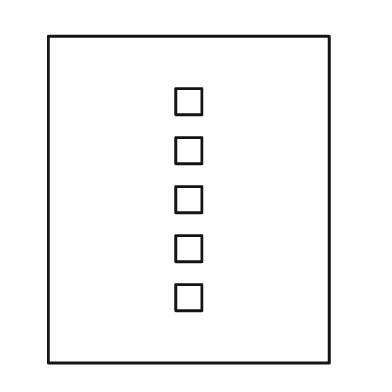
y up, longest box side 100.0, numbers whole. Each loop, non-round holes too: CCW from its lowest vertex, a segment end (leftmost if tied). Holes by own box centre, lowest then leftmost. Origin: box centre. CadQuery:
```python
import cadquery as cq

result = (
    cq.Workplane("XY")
    .moveTo(-43.0, -50.0)
    .lineTo(43.0, -50.0)
    .lineTo(43.0, 50.0)
    .lineTo(-43.0, 50.0)
    .close()
    .moveTo(-4.0, -34.0)
    .lineTo(4.0, -34.0)
    .lineTo(4.0, -26.0)
    .lineTo(-4.0, -26.0)
    .close()
    .moveTo(-4.0, -19.0)
    .lineTo(4.0, -19.0)
    .lineTo(4.0, -11.0)
    .lineTo(-4.0, -11.0)
    .close()
    .moveTo(-4.0, -4.0)
    .lineTo(4.0, -4.0)
    .lineTo(4.0, 4.0)
    .lineTo(-4.0, 4.0)
    .close()
    .moveTo(-4.0, 11.0)
    .lineTo(4.0, 11.0)
    .lineTo(4.0, 19.0)
    .lineTo(-4.0, 19.0)
    .close()
    .moveTo(-4.0, 26.0)
    .lineTo(4.0, 26.0)
    .lineTo(4.0, 34.0)
    .lineTo(-4.0, 34.0)
    .close()
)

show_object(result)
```